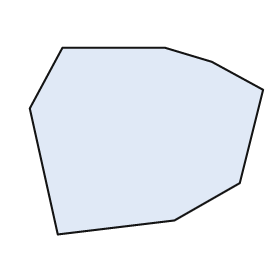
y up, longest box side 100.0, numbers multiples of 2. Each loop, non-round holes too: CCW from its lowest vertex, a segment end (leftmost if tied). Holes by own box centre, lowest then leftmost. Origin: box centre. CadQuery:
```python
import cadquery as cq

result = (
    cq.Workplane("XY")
    .moveTo(-38.0, -40.0)
    .lineTo(12.0, -34.0)
    .lineTo(40.0, -18.0)
    .lineTo(50.0, 22.0)
    .lineTo(28.0, 34.0)
    .lineTo(8.0, 40.0)
    .lineTo(-36.0, 40.0)
    .lineTo(-50.0, 14.0)
    .close()
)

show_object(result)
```